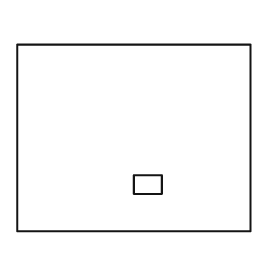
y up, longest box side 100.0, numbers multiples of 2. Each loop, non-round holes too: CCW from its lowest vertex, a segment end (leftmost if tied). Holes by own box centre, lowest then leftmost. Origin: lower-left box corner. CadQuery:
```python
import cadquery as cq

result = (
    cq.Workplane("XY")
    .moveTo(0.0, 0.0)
    .lineTo(100.0, 0.0)
    .lineTo(100.0, 80.0)
    .lineTo(0.0, 80.0)
    .close()
    .moveTo(50.0, 16.0)
    .lineTo(62.0, 16.0)
    .lineTo(62.0, 24.0)
    .lineTo(50.0, 24.0)
    .close()
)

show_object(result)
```